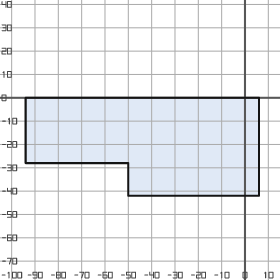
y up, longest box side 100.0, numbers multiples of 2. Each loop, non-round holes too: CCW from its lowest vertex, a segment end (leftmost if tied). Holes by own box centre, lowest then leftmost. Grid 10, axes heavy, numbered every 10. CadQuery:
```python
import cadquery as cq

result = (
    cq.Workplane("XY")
    .moveTo(-50.0, -42.0)
    .lineTo(6.0, -42.0)
    .lineTo(6.0, 0.0)
    .lineTo(-94.0, 0.0)
    .lineTo(-94.0, -28.0)
    .lineTo(-50.0, -28.0)
    .close()
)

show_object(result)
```